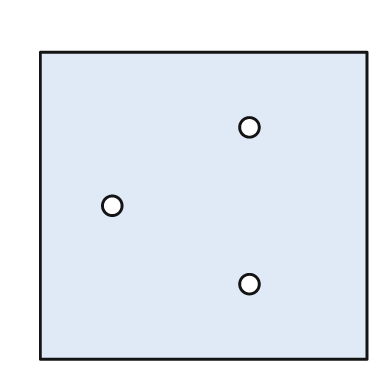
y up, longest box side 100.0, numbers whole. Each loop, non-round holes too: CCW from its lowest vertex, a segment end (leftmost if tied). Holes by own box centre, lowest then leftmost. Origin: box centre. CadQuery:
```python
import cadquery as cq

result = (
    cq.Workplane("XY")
    .moveTo(-50.0, -47.0)
    .lineTo(50.0, -47.0)
    .lineTo(50.0, 47.0)
    .lineTo(-50.0, 47.0)
    .close()
    .moveTo(14.0, -24.0)
    .circle(3.0)
    .moveTo(-28.0, 0.0)
    .circle(3.0)
    .moveTo(14.0, 24.0)
    .circle(3.0)
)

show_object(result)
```